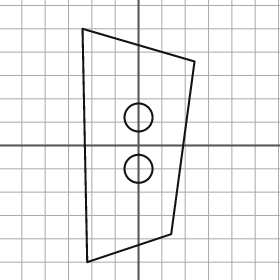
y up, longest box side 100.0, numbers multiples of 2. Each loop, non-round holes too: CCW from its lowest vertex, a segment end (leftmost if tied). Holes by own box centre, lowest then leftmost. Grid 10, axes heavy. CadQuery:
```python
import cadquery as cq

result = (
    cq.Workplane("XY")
    .moveTo(-22.0, -50.0)
    .lineTo(14.0, -38.0)
    .lineTo(24.0, 36.0)
    .lineTo(-24.0, 50.0)
    .close()
    .moveTo(0.0, -10.0)
    .circle(6.0)
    .moveTo(0.0, 12.0)
    .circle(6.0)
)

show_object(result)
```